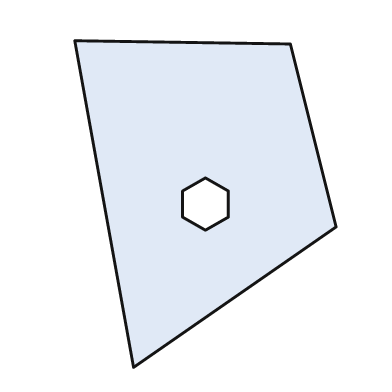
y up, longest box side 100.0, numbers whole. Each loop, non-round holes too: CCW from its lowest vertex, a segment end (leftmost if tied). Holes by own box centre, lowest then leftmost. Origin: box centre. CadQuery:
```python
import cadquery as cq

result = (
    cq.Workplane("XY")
    .moveTo(-22.0, -50.0)
    .lineTo(40.0, -7.0)
    .lineTo(26.0, 49.0)
    .lineTo(-40.0, 50.0)
    .close()
    .moveTo(0.0, -8.0)
    .lineTo(7.0, -4.0)
    .lineTo(7.0, 4.0)
    .lineTo(0.0, 8.0)
    .lineTo(-7.0, 4.0)
    .lineTo(-7.0, -4.0)
    .close()
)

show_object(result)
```